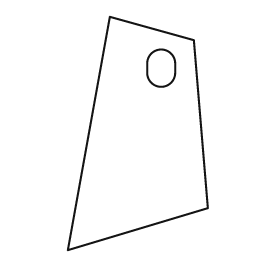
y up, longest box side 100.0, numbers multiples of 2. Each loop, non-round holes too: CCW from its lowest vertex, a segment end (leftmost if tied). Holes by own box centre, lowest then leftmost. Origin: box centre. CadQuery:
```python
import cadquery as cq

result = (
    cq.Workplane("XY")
    .moveTo(-30.0, -50.0)
    .lineTo(30.0, -32.0)
    .lineTo(24.0, 40.0)
    .lineTo(-12.0, 50.0)
    .close()
    .moveTo(4.0, 26.0)
    .threePointArc((10.0, 20.0), (16.0, 26.0))
    .lineTo(16.0, 30.0)
    .threePointArc((10.0, 36.0), (4.0, 30.0))
    .close()
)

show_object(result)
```